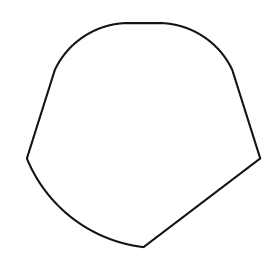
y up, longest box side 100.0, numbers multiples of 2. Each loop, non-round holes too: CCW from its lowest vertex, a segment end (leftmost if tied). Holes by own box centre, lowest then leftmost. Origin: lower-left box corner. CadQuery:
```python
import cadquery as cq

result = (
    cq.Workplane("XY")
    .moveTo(50.0, 0.0)
    .lineTo(100.0, 38.0)
    .lineTo(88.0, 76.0)
    .threePointArc((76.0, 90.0), (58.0, 96.0))
    .lineTo(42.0, 96.0)
    .threePointArc((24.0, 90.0), (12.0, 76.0))
    .lineTo(0.0, 38.0)
    .threePointArc((20.0, 12.0), (50.0, 0.0))
    .close()
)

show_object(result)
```